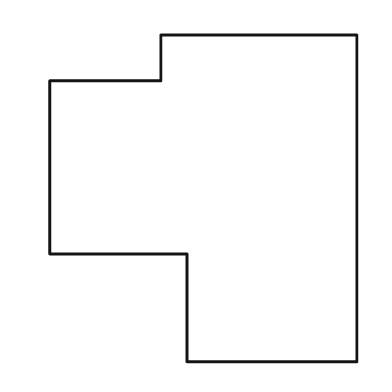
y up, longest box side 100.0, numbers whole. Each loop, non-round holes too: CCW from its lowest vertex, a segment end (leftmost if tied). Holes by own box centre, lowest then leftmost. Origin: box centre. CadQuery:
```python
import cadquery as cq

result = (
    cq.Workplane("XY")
    .moveTo(-5.0, -50.0)
    .lineTo(47.0, -50.0)
    .lineTo(47.0, 50.0)
    .lineTo(-13.0, 50.0)
    .lineTo(-13.0, 36.0)
    .lineTo(-47.0, 36.0)
    .lineTo(-47.0, -17.0)
    .lineTo(-5.0, -17.0)
    .close()
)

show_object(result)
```